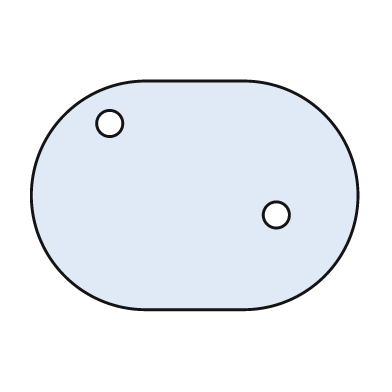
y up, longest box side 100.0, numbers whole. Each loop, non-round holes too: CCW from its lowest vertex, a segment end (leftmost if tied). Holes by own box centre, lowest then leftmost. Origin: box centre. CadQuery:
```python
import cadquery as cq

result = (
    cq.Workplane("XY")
    .moveTo(-15.0, -35.0)
    .lineTo(15.0, -35.0)
    .threePointArc((50.0, 0.0), (15.0, 35.0))
    .lineTo(-15.0, 35.0)
    .threePointArc((-50.0, 0.0), (-15.0, -35.0))
    .close()
    .moveTo(25.0, -6.0)
    .circle(4.0)
    .moveTo(-26.0, 22.0)
    .circle(4.0)
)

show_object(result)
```